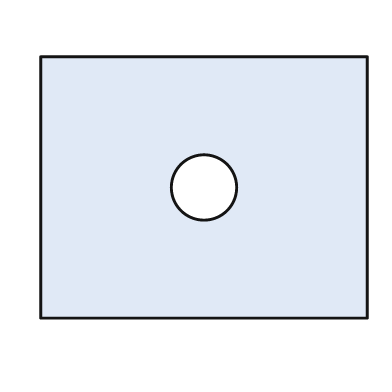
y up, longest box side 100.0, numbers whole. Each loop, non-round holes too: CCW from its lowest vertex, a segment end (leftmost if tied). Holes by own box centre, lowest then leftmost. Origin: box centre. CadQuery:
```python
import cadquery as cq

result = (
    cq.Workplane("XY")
    .moveTo(-50.0, -40.0)
    .lineTo(50.0, -40.0)
    .lineTo(50.0, 40.0)
    .lineTo(-50.0, 40.0)
    .close()
    .moveTo(0.0, 0.0)
    .circle(10.0)
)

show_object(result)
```